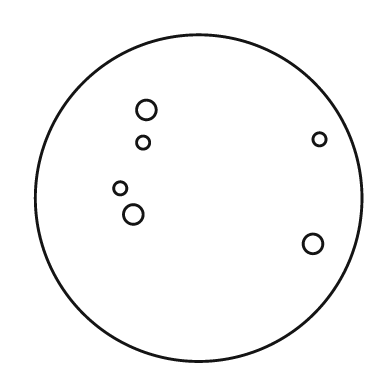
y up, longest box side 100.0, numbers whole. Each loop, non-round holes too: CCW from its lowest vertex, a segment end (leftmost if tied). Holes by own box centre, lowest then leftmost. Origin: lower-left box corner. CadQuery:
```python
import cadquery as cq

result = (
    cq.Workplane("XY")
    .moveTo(50.0, 50.0)
    .circle(50.0)
    .moveTo(85.0, 36.0)
    .circle(3.0)
    .moveTo(30.0, 45.0)
    .circle(3.0)
    .moveTo(26.0, 53.0)
    .circle(2.0)
    .moveTo(33.0, 67.0)
    .circle(2.0)
    .moveTo(87.0, 68.0)
    .circle(2.0)
    .moveTo(34.0, 77.0)
    .circle(3.0)
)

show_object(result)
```